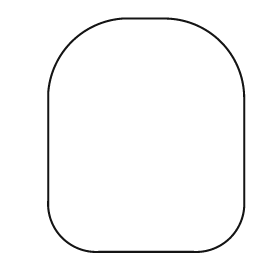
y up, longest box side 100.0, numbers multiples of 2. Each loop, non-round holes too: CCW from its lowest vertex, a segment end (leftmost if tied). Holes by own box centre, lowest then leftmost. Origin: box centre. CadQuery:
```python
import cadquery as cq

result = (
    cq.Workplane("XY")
    .moveTo(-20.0, -50.0)
    .lineTo(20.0, -50.0)
    .threePointArc((36.0, -44.0), (42.0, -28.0))
    .lineTo(42.0, 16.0)
    .threePointArc((32.0, 40.0), (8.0, 50.0))
    .lineTo(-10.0, 50.0)
    .threePointArc((-32.0, 40.0), (-42.0, 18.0))
    .lineTo(-42.0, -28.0)
    .threePointArc((-36.0, -44.0), (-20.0, -50.0))
    .close()
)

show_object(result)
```